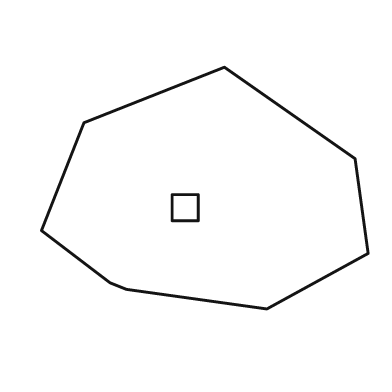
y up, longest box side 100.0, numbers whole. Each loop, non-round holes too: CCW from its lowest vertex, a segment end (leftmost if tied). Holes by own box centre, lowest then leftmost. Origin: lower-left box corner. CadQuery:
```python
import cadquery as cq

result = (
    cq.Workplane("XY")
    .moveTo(69.0, 0.0)
    .lineTo(100.0, 17.0)
    .lineTo(96.0, 46.0)
    .lineTo(56.0, 74.0)
    .lineTo(13.0, 57.0)
    .lineTo(0.0, 24.0)
    .lineTo(21.0, 8.0)
    .lineTo(26.0, 6.0)
    .close()
    .moveTo(40.0, 27.0)
    .lineTo(48.0, 27.0)
    .lineTo(48.0, 35.0)
    .lineTo(40.0, 35.0)
    .close()
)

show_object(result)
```